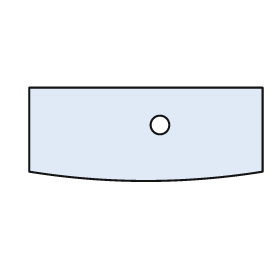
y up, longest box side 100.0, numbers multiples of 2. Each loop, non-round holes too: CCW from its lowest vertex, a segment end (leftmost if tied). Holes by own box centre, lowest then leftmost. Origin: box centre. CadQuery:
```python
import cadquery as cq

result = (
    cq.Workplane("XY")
    .moveTo(-50.0, -16.0)
    .threePointArc((0.0, -20.0), (50.0, -16.0))
    .lineTo(50.0, 20.0)
    .lineTo(-50.0, 20.0)
    .close()
    .moveTo(6.0, 4.0)
    .circle(4.0)
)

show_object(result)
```